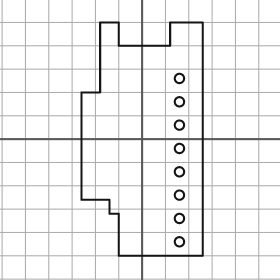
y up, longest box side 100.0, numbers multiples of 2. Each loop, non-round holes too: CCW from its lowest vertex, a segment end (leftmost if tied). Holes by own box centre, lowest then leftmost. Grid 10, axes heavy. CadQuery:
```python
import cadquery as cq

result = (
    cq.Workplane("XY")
    .moveTo(-10.0, -50.0)
    .lineTo(26.0, -50.0)
    .lineTo(26.0, 50.0)
    .lineTo(12.0, 50.0)
    .lineTo(12.0, 40.0)
    .lineTo(-10.0, 40.0)
    .lineTo(-10.0, 50.0)
    .lineTo(-18.0, 50.0)
    .lineTo(-18.0, 20.0)
    .lineTo(-26.0, 20.0)
    .lineTo(-26.0, -26.0)
    .lineTo(-14.0, -26.0)
    .lineTo(-14.0, -32.0)
    .lineTo(-10.0, -32.0)
    .close()
    .moveTo(16.0, -44.0)
    .circle(2.0)
    .moveTo(16.0, -34.0)
    .circle(2.0)
    .moveTo(16.0, -24.0)
    .circle(2.0)
    .moveTo(16.0, -14.0)
    .circle(2.0)
    .moveTo(16.0, -4.0)
    .circle(2.0)
    .moveTo(16.0, 6.0)
    .circle(2.0)
    .moveTo(16.0, 16.0)
    .circle(2.0)
    .moveTo(16.0, 26.0)
    .circle(2.0)
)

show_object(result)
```